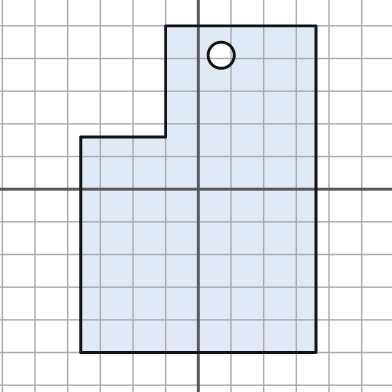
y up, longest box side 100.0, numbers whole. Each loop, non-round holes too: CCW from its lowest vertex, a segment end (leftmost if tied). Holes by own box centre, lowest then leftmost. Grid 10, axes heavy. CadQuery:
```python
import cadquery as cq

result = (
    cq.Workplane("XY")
    .moveTo(-36.0, -50.0)
    .lineTo(36.0, -50.0)
    .lineTo(36.0, 50.0)
    .lineTo(-10.0, 50.0)
    .lineTo(-10.0, 16.0)
    .lineTo(-36.0, 16.0)
    .close()
    .moveTo(7.0, 41.0)
    .circle(4.0)
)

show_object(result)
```